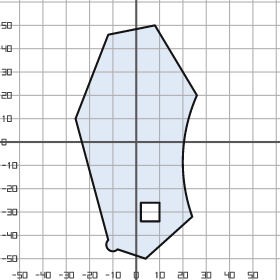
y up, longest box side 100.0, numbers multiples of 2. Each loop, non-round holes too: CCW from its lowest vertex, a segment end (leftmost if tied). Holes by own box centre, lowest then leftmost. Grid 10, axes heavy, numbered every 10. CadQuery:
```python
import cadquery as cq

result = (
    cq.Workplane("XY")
    .moveTo(4.0, -50.0)
    .lineTo(24.0, -32.0)
    .threePointArc((20.0, -6.0), (26.0, 20.0))
    .lineTo(8.0, 50.0)
    .lineTo(-12.0, 46.0)
    .lineTo(-26.0, 10.0)
    .lineTo(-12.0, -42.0)
    .threePointArc((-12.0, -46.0), (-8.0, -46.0))
    .close()
    .moveTo(2.0, -34.0)
    .lineTo(10.0, -34.0)
    .lineTo(10.0, -26.0)
    .lineTo(2.0, -26.0)
    .close()
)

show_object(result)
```